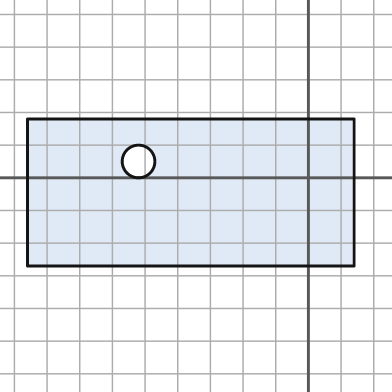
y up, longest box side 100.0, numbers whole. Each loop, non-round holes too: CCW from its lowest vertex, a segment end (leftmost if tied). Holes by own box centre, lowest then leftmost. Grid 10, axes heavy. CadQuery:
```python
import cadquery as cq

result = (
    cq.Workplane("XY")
    .moveTo(-86.0, -27.0)
    .lineTo(14.0, -27.0)
    .lineTo(14.0, 18.0)
    .lineTo(-86.0, 18.0)
    .close()
    .moveTo(-52.0, 5.0)
    .circle(5.0)
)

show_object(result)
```